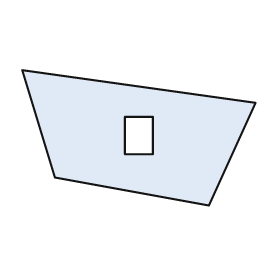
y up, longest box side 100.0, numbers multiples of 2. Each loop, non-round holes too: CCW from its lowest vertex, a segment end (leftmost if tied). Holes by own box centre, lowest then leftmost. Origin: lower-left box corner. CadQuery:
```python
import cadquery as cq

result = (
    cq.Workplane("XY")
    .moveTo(80.0, 0.0)
    .lineTo(100.0, 44.0)
    .lineTo(0.0, 58.0)
    .lineTo(14.0, 12.0)
    .close()
    .moveTo(44.0, 22.0)
    .lineTo(56.0, 22.0)
    .lineTo(56.0, 38.0)
    .lineTo(44.0, 38.0)
    .close()
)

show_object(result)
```